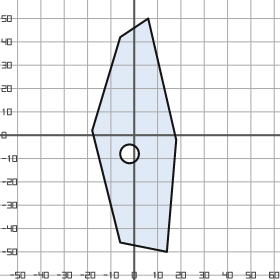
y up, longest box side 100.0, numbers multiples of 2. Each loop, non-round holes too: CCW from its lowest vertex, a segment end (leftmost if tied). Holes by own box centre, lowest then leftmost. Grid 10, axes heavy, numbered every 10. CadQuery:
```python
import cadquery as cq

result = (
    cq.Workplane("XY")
    .moveTo(14.0, -50.0)
    .lineTo(18.0, -2.0)
    .lineTo(6.0, 50.0)
    .lineTo(-6.0, 42.0)
    .lineTo(-18.0, 2.0)
    .lineTo(-6.0, -46.0)
    .close()
    .moveTo(-2.0, -8.0)
    .circle(4.0)
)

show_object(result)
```